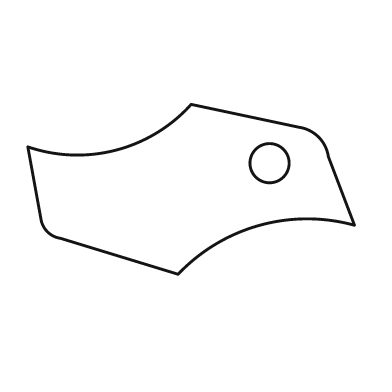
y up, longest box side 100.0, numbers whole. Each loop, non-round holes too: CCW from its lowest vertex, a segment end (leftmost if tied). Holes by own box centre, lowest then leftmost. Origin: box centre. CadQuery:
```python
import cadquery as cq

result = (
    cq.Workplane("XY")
    .moveTo(-4.0, -26.0)
    .threePointArc((21.0, -11.0), (50.0, -11.0))
    .lineTo(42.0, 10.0)
    .threePointArc((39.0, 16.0), (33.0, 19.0))
    .lineTo(0.0, 26.0)
    .threePointArc((-23.0, 12.0), (-50.0, 13.0))
    .lineTo(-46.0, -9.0)
    .threePointArc((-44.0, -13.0), (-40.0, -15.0))
    .close()
    .moveTo(24.0, 8.0)
    .circle(6.0)
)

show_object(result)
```